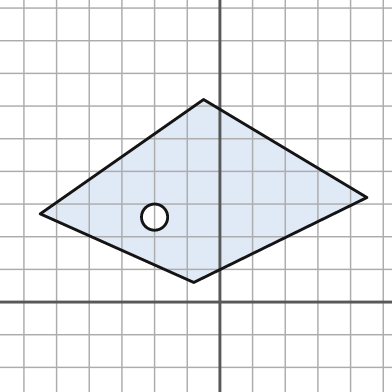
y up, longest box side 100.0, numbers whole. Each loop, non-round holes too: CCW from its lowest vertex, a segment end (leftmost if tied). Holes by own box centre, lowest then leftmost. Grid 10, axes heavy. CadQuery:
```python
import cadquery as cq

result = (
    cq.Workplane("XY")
    .moveTo(-8.0, 6.0)
    .lineTo(45.0, 32.0)
    .lineTo(-5.0, 62.0)
    .lineTo(-55.0, 27.0)
    .close()
    .moveTo(-20.0, 26.0)
    .circle(4.0)
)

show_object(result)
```